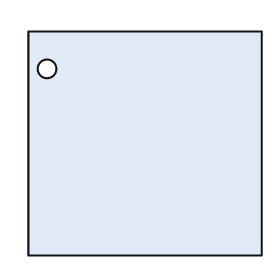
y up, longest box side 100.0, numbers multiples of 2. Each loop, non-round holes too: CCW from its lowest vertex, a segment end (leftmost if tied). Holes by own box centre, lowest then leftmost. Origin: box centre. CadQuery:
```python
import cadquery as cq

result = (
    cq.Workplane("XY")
    .moveTo(-50.0, -48.0)
    .lineTo(50.0, -48.0)
    .lineTo(50.0, 48.0)
    .lineTo(-50.0, 48.0)
    .close()
    .moveTo(-42.0, 32.0)
    .circle(4.0)
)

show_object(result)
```